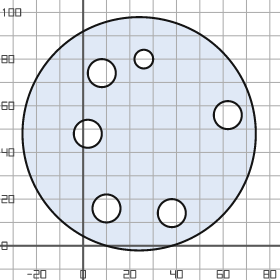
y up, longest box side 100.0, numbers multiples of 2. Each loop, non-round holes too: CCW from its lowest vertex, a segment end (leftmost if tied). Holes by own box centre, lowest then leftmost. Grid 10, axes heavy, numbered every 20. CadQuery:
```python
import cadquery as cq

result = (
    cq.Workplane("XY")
    .moveTo(24.0, 48.0)
    .circle(50.0)
    .moveTo(38.0, 14.0)
    .circle(6.0)
    .moveTo(10.0, 16.0)
    .circle(6.0)
    .moveTo(2.0, 48.0)
    .circle(6.0)
    .moveTo(62.0, 56.0)
    .circle(6.0)
    .moveTo(8.0, 74.0)
    .circle(6.0)
    .moveTo(26.0, 80.0)
    .circle(4.0)
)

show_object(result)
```